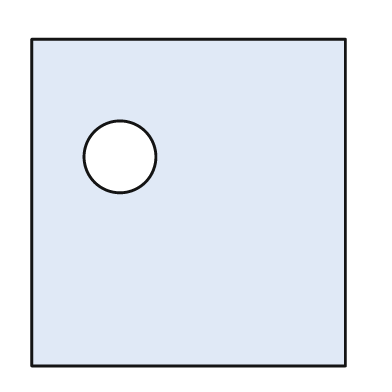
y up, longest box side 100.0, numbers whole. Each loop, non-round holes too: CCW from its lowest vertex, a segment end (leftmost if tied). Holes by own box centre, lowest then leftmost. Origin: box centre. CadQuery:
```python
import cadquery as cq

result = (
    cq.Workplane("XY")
    .moveTo(-48.0, -50.0)
    .lineTo(48.0, -50.0)
    .lineTo(48.0, 50.0)
    .lineTo(-48.0, 50.0)
    .close()
    .moveTo(-21.0, 14.0)
    .circle(11.0)
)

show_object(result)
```